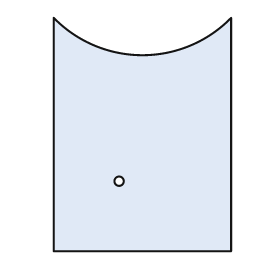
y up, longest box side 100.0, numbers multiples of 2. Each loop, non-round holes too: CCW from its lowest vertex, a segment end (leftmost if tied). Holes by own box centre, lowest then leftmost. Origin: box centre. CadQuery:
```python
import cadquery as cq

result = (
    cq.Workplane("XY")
    .moveTo(-38.0, -50.0)
    .lineTo(38.0, -50.0)
    .lineTo(38.0, 50.0)
    .threePointArc((0.0, 34.0), (-38.0, 50.0))
    .close()
    .moveTo(-10.0, -20.0)
    .circle(2.0)
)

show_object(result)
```